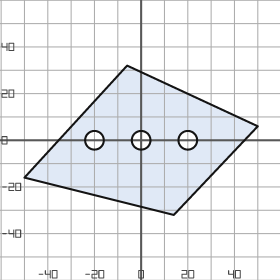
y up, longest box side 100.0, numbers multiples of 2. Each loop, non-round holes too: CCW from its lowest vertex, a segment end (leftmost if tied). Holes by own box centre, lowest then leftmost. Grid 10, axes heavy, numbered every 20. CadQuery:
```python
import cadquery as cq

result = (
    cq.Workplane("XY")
    .moveTo(14.0, -32.0)
    .lineTo(50.0, 6.0)
    .lineTo(-6.0, 32.0)
    .lineTo(-50.0, -16.0)
    .close()
    .moveTo(-20.0, 0.0)
    .circle(4.0)
    .moveTo(0.0, 0.0)
    .circle(4.0)
    .moveTo(20.0, 0.0)
    .circle(4.0)
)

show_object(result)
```